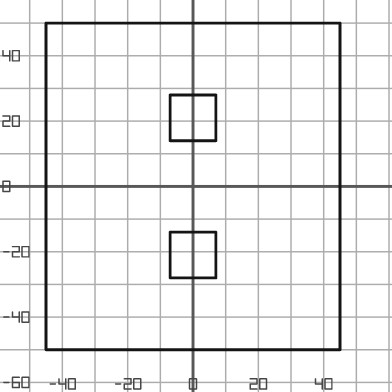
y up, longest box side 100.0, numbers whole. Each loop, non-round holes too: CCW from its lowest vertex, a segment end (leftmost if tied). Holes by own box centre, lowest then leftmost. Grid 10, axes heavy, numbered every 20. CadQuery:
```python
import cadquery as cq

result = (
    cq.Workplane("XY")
    .moveTo(-45.0, -50.0)
    .lineTo(45.0, -50.0)
    .lineTo(45.0, 50.0)
    .lineTo(-45.0, 50.0)
    .close()
    .moveTo(-7.0, -28.0)
    .lineTo(7.0, -28.0)
    .lineTo(7.0, -14.0)
    .lineTo(-7.0, -14.0)
    .close()
    .moveTo(-7.0, 14.0)
    .lineTo(7.0, 14.0)
    .lineTo(7.0, 28.0)
    .lineTo(-7.0, 28.0)
    .close()
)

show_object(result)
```